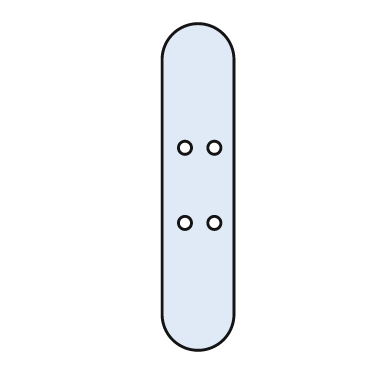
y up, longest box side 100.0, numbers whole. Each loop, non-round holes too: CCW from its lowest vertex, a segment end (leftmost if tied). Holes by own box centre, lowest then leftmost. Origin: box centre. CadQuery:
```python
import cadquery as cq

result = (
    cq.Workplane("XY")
    .moveTo(-11.0, -39.0)
    .threePointArc((0.0, -50.0), (11.0, -39.0))
    .lineTo(11.0, 39.0)
    .threePointArc((0.0, 50.0), (-11.0, 39.0))
    .close()
    .moveTo(-4.0, -11.0)
    .circle(2.0)
    .moveTo(5.0, -11.0)
    .circle(2.0)
    .moveTo(-4.0, 12.0)
    .circle(2.0)
    .moveTo(5.0, 12.0)
    .circle(2.0)
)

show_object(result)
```